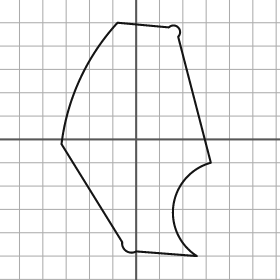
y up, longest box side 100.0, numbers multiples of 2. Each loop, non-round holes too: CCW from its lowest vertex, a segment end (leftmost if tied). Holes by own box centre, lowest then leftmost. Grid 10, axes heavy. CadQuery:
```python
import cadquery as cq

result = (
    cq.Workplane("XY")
    .moveTo(26.0, -50.0)
    .threePointArc((16.0, -28.0), (32.0, -10.0))
    .lineTo(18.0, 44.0)
    .threePointArc((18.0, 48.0), (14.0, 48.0))
    .lineTo(-8.0, 50.0)
    .threePointArc((-24.0, 26.0), (-32.0, -2.0))
    .lineTo(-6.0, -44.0)
    .threePointArc((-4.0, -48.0), (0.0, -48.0))
    .close()
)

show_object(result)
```